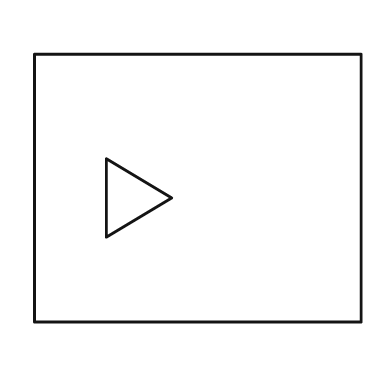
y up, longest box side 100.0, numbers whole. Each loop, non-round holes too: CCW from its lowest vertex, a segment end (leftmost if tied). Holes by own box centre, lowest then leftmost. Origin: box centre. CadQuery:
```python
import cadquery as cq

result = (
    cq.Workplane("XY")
    .moveTo(-50.0, -41.0)
    .lineTo(50.0, -41.0)
    .lineTo(50.0, 41.0)
    .lineTo(-50.0, 41.0)
    .close()
    .moveTo(-28.0, -15.0)
    .lineTo(-8.0, -3.0)
    .lineTo(-28.0, 9.0)
    .close()
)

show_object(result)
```